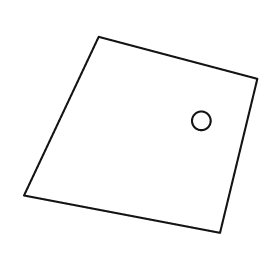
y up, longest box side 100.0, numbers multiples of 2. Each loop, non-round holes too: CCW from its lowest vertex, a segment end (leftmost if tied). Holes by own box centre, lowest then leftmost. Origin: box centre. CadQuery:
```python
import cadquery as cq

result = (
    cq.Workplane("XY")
    .moveTo(34.0, -42.0)
    .lineTo(50.0, 24.0)
    .lineTo(-18.0, 42.0)
    .lineTo(-50.0, -26.0)
    .close()
    .moveTo(26.0, 6.0)
    .circle(4.0)
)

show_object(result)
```